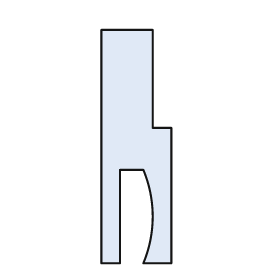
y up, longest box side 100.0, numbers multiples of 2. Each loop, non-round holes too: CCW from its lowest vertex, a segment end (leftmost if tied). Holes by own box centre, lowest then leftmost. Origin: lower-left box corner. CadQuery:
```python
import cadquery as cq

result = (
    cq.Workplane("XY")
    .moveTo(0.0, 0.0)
    .lineTo(8.0, 0.0)
    .lineTo(8.0, 40.0)
    .lineTo(18.0, 40.0)
    .threePointArc((22.0, 20.0), (18.0, 0.0))
    .lineTo(30.0, 0.0)
    .lineTo(30.0, 58.0)
    .lineTo(22.0, 58.0)
    .lineTo(22.0, 100.0)
    .lineTo(0.0, 100.0)
    .close()
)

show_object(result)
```